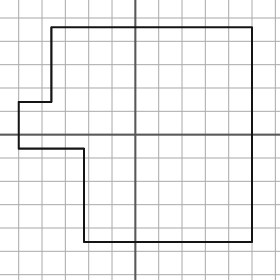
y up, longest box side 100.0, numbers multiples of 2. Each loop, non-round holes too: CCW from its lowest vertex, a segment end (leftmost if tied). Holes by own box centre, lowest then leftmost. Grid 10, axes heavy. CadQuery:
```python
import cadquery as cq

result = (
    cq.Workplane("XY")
    .moveTo(-22.0, -46.0)
    .lineTo(50.0, -46.0)
    .lineTo(50.0, 46.0)
    .lineTo(-36.0, 46.0)
    .lineTo(-36.0, 14.0)
    .lineTo(-50.0, 14.0)
    .lineTo(-50.0, -6.0)
    .lineTo(-22.0, -6.0)
    .close()
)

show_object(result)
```